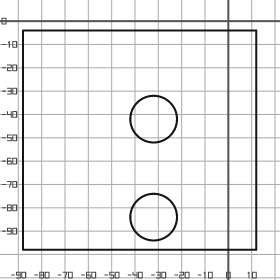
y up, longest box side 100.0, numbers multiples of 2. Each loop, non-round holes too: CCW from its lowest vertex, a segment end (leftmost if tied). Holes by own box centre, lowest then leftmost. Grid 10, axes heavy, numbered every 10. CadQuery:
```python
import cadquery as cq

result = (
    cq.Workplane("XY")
    .moveTo(-88.0, -98.0)
    .lineTo(12.0, -98.0)
    .lineTo(12.0, -4.0)
    .lineTo(-88.0, -4.0)
    .close()
    .moveTo(-32.0, -84.0)
    .circle(10.0)
    .moveTo(-32.0, -42.0)
    .circle(10.0)
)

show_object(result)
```